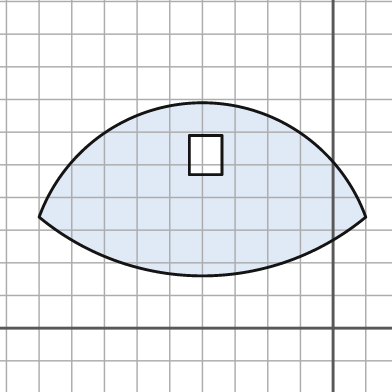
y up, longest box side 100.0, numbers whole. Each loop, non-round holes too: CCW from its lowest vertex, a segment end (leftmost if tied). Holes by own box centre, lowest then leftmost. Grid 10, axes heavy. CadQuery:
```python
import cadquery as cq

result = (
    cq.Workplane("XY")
    .moveTo(-90.0, 34.0)
    .threePointArc((-40.0, 16.0), (10.0, 34.0))
    .threePointArc((-40.0, 69.0), (-90.0, 34.0))
    .close()
    .moveTo(-44.0, 47.0)
    .lineTo(-34.0, 47.0)
    .lineTo(-34.0, 59.0)
    .lineTo(-44.0, 59.0)
    .close()
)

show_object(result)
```